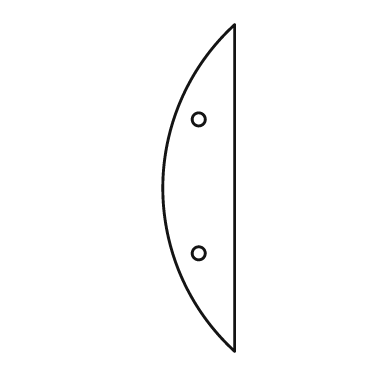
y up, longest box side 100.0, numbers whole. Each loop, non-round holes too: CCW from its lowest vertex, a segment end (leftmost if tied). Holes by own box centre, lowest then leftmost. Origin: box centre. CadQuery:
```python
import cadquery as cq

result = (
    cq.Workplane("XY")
    .moveTo(11.0, -50.0)
    .lineTo(11.0, 50.0)
    .threePointArc((-11.0, 0.0), (11.0, -50.0))
    .close()
    .moveTo(0.0, -20.0)
    .circle(2.0)
    .moveTo(0.0, 21.0)
    .circle(2.0)
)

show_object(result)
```